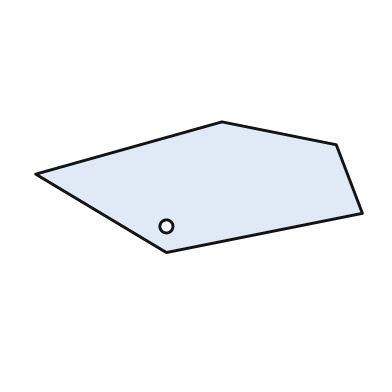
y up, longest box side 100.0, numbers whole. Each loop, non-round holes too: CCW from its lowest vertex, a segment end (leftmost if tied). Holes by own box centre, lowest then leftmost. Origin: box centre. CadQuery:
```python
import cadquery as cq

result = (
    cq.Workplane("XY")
    .moveTo(-10.0, -20.0)
    .lineTo(50.0, -8.0)
    .lineTo(42.0, 13.0)
    .lineTo(7.0, 20.0)
    .lineTo(-50.0, 4.0)
    .close()
    .moveTo(-10.0, -12.0)
    .circle(2.0)
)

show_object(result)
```